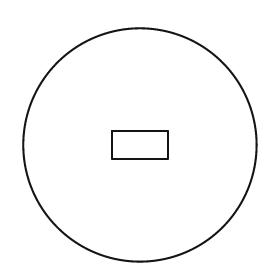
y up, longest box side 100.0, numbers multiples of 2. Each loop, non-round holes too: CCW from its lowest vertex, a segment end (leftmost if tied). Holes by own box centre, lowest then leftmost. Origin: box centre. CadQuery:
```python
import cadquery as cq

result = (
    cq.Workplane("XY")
    .moveTo(0.0, 0.0)
    .circle(50.0)
    .moveTo(-12.0, -6.0)
    .lineTo(12.0, -6.0)
    .lineTo(12.0, 6.0)
    .lineTo(-12.0, 6.0)
    .close()
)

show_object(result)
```